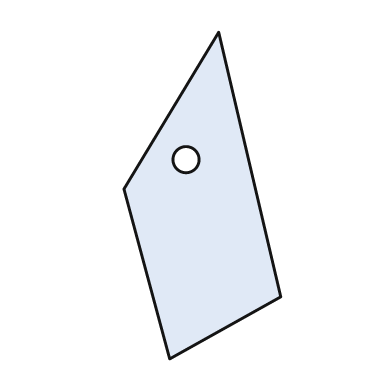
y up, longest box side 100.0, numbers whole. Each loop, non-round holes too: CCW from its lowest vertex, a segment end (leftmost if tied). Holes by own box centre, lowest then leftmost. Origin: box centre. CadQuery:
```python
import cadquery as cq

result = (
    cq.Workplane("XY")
    .moveTo(-10.0, -50.0)
    .lineTo(24.0, -31.0)
    .lineTo(5.0, 50.0)
    .lineTo(-24.0, 2.0)
    .close()
    .moveTo(-5.0, 11.0)
    .circle(4.0)
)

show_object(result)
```